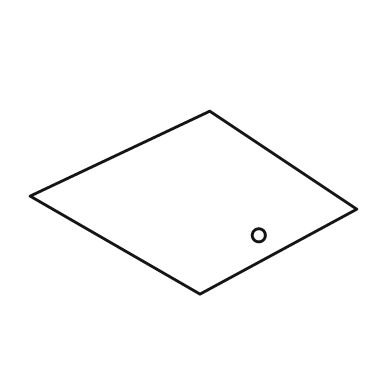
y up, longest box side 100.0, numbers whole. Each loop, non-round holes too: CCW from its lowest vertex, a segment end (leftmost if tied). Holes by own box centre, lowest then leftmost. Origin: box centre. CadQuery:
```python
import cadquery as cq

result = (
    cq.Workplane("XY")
    .moveTo(2.0, -28.0)
    .lineTo(50.0, -2.0)
    .lineTo(5.0, 28.0)
    .lineTo(-50.0, 2.0)
    .close()
    .moveTo(20.0, -10.0)
    .circle(2.0)
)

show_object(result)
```